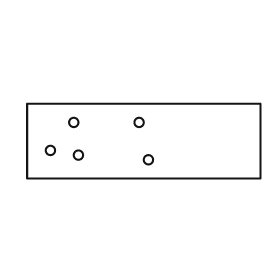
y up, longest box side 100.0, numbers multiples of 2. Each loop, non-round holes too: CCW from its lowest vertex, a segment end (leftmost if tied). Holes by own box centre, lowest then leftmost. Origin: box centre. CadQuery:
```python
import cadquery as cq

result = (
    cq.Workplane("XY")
    .moveTo(-50.0, -16.0)
    .lineTo(50.0, -16.0)
    .lineTo(50.0, 16.0)
    .lineTo(-50.0, 16.0)
    .close()
    .moveTo(2.0, -8.0)
    .circle(2.0)
    .moveTo(-28.0, -6.0)
    .circle(2.0)
    .moveTo(-40.0, -4.0)
    .circle(2.0)
    .moveTo(-30.0, 8.0)
    .circle(2.0)
    .moveTo(-2.0, 8.0)
    .circle(2.0)
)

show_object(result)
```